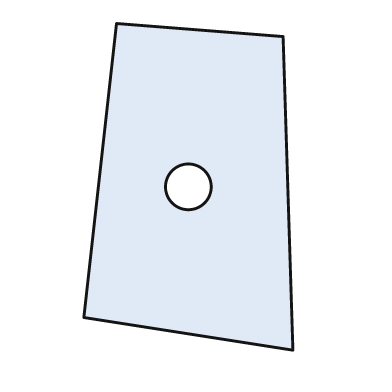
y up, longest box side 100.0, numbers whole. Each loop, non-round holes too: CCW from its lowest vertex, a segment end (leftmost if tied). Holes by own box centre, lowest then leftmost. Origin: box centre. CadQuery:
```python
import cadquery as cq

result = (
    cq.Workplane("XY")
    .moveTo(32.0, -50.0)
    .lineTo(29.0, 46.0)
    .lineTo(-22.0, 50.0)
    .lineTo(-32.0, -40.0)
    .close()
    .moveTo(0.0, 0.0)
    .circle(7.0)
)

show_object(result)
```